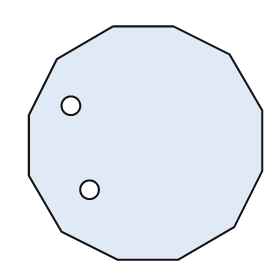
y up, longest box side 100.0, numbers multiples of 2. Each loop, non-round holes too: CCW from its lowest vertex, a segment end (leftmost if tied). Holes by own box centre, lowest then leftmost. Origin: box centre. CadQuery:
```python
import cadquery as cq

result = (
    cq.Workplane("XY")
    .moveTo(-12.0, -50.0)
    .lineTo(14.0, -50.0)
    .lineTo(38.0, -36.0)
    .lineTo(50.0, -12.0)
    .lineTo(50.0, 14.0)
    .lineTo(36.0, 38.0)
    .lineTo(12.0, 50.0)
    .lineTo(-14.0, 50.0)
    .lineTo(-38.0, 36.0)
    .lineTo(-50.0, 12.0)
    .lineTo(-50.0, -14.0)
    .lineTo(-36.0, -38.0)
    .close()
    .moveTo(-24.0, -20.0)
    .circle(4.0)
    .moveTo(-32.0, 16.0)
    .circle(4.0)
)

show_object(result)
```